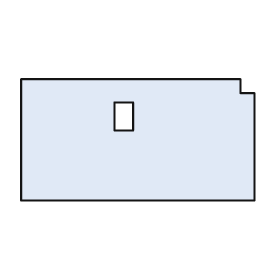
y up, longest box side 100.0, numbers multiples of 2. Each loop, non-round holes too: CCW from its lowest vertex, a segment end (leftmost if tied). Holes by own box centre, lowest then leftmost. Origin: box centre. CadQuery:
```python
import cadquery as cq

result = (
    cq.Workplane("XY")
    .moveTo(-50.0, -26.0)
    .lineTo(50.0, -26.0)
    .lineTo(50.0, 20.0)
    .lineTo(44.0, 20.0)
    .lineTo(44.0, 26.0)
    .lineTo(-50.0, 26.0)
    .close()
    .moveTo(-10.0, 4.0)
    .lineTo(-2.0, 4.0)
    .lineTo(-2.0, 16.0)
    .lineTo(-10.0, 16.0)
    .close()
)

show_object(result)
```